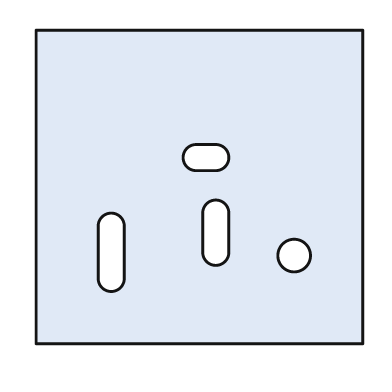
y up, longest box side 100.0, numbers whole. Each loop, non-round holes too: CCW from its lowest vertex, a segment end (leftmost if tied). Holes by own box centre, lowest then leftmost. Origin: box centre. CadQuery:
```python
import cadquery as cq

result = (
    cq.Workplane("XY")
    .moveTo(-50.0, -48.0)
    .lineTo(50.0, -48.0)
    .lineTo(50.0, 48.0)
    .lineTo(-50.0, 48.0)
    .close()
    .moveTo(29.0, -21.0)
    .circle(5.0)
    .moveTo(-31.0, -28.0)
    .threePointArc((-27.0, -32.0), (-23.0, -28.0))
    .lineTo(-23.0, -12.0)
    .threePointArc((-27.0, -8.0), (-31.0, -12.0))
    .close()
    .moveTo(1.0, -20.0)
    .threePointArc((5.0, -24.0), (9.0, -20.0))
    .lineTo(9.0, -8.0)
    .threePointArc((5.0, -4.0), (1.0, -8.0))
    .close()
    .moveTo(-1.0, 5.0)
    .lineTo(5.0, 5.0)
    .threePointArc((9.0, 9.0), (5.0, 13.0))
    .lineTo(-1.0, 13.0)
    .threePointArc((-5.0, 9.0), (-1.0, 5.0))
    .close()
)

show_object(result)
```